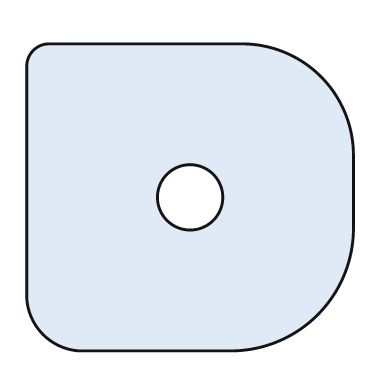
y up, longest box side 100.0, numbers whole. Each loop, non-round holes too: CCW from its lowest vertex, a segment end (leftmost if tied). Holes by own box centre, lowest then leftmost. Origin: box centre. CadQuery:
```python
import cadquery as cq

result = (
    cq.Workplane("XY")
    .moveTo(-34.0, -47.0)
    .lineTo(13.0, -47.0)
    .threePointArc((39.0, -36.0), (50.0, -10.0))
    .lineTo(50.0, 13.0)
    .threePointArc((40.0, 37.0), (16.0, 47.0))
    .lineTo(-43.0, 47.0)
    .threePointArc((-48.0, 45.0), (-50.0, 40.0))
    .lineTo(-50.0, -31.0)
    .threePointArc((-45.0, -42.0), (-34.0, -47.0))
    .close()
    .moveTo(0.0, 0.0)
    .circle(10.0)
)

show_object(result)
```